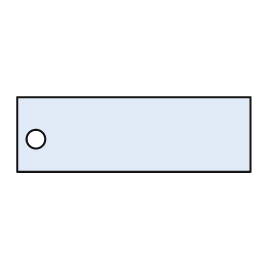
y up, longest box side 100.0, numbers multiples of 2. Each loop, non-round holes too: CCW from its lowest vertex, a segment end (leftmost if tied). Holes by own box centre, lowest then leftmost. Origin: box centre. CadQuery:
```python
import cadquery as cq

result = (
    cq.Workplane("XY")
    .moveTo(-50.0, -16.0)
    .lineTo(50.0, -16.0)
    .lineTo(50.0, 16.0)
    .lineTo(-50.0, 16.0)
    .close()
    .moveTo(-42.0, -2.0)
    .circle(4.0)
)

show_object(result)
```